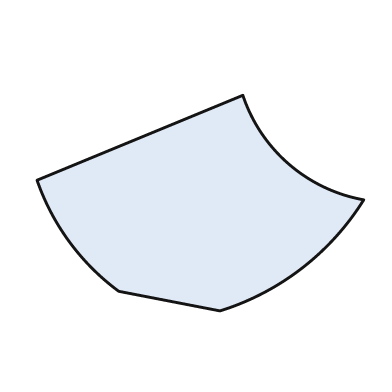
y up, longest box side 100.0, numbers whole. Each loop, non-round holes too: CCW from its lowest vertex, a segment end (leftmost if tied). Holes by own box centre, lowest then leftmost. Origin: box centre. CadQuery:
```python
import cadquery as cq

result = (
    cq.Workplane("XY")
    .moveTo(6.0, -33.0)
    .threePointArc((31.0, -20.0), (50.0, 1.0))
    .threePointArc((27.0, 12.0), (13.0, 33.0))
    .lineTo(-50.0, 7.0)
    .threePointArc((-40.0, -12.0), (-25.0, -27.0))
    .close()
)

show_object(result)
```